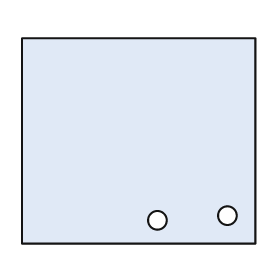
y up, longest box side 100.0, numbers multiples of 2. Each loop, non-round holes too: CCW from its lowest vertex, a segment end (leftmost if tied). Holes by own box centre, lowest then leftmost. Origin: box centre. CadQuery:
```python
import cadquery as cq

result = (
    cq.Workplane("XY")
    .moveTo(-50.0, -44.0)
    .lineTo(50.0, -44.0)
    .lineTo(50.0, 44.0)
    .lineTo(-50.0, 44.0)
    .close()
    .moveTo(8.0, -34.0)
    .circle(4.0)
    .moveTo(38.0, -32.0)
    .circle(4.0)
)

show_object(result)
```